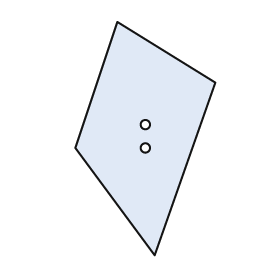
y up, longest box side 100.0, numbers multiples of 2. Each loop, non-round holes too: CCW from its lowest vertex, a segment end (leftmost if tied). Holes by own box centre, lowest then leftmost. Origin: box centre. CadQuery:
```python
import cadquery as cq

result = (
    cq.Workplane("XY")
    .moveTo(4.0, -50.0)
    .lineTo(30.0, 24.0)
    .lineTo(-12.0, 50.0)
    .lineTo(-30.0, -4.0)
    .close()
    .moveTo(0.0, -4.0)
    .circle(2.0)
    .moveTo(0.0, 6.0)
    .circle(2.0)
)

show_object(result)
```